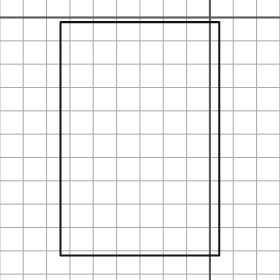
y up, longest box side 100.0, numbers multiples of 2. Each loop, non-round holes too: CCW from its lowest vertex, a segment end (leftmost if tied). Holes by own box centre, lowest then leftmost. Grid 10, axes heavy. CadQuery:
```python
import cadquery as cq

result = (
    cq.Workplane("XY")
    .moveTo(-64.0, -102.0)
    .lineTo(4.0, -102.0)
    .lineTo(4.0, -2.0)
    .lineTo(-64.0, -2.0)
    .close()
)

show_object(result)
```